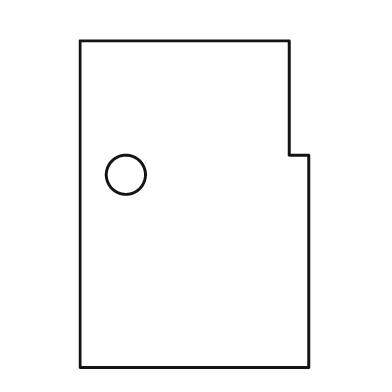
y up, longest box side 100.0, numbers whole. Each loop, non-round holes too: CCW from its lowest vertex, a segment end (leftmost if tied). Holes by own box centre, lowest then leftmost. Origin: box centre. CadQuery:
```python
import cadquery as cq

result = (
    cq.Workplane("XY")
    .moveTo(-35.0, -50.0)
    .lineTo(35.0, -50.0)
    .lineTo(35.0, 15.0)
    .lineTo(29.0, 15.0)
    .lineTo(29.0, 50.0)
    .lineTo(-35.0, 50.0)
    .close()
    .moveTo(-21.0, 9.0)
    .circle(6.0)
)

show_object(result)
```